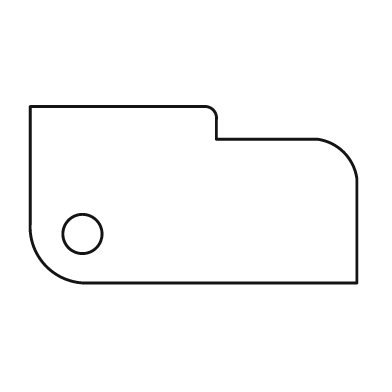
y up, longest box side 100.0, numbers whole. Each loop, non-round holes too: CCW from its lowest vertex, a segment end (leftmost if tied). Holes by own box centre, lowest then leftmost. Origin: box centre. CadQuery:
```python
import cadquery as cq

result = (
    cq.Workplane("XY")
    .moveTo(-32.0, -27.0)
    .lineTo(50.0, -27.0)
    .lineTo(50.0, 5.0)
    .threePointArc((46.0, 13.0), (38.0, 17.0))
    .lineTo(7.0, 17.0)
    .lineTo(7.0, 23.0)
    .threePointArc((6.0, 26.0), (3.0, 27.0))
    .lineTo(-50.0, 27.0)
    .lineTo(-50.0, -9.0)
    .threePointArc((-45.0, -22.0), (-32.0, -27.0))
    .close()
    .moveTo(-34.0, -12.0)
    .circle(6.0)
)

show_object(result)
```